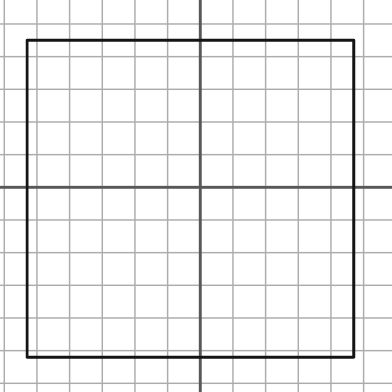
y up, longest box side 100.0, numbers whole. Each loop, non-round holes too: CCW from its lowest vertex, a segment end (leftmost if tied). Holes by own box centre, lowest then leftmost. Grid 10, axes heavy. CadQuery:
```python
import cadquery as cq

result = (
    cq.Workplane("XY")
    .moveTo(-53.0, -52.0)
    .lineTo(47.0, -52.0)
    .lineTo(47.0, 45.0)
    .lineTo(-53.0, 45.0)
    .close()
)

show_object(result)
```